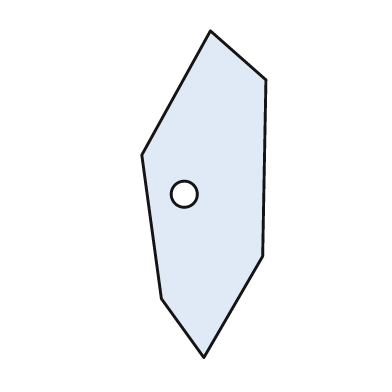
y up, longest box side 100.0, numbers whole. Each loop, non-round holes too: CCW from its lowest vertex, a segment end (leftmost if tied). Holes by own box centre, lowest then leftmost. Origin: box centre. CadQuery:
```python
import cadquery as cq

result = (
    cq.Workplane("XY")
    .moveTo(0.0, -50.0)
    .lineTo(18.0, -19.0)
    .lineTo(19.0, 35.0)
    .lineTo(2.0, 50.0)
    .lineTo(-19.0, 12.0)
    .lineTo(-13.0, -32.0)
    .close()
    .moveTo(-6.0, 0.0)
    .circle(4.0)
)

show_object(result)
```